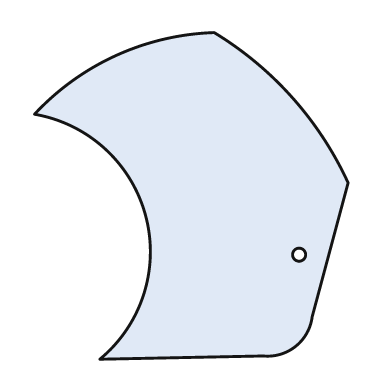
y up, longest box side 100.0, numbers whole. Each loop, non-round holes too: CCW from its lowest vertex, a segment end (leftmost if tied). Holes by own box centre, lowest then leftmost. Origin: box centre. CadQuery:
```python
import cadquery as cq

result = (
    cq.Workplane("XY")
    .moveTo(-28.0, -50.0)
    .lineTo(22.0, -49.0)
    .threePointArc((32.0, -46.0), (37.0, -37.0))
    .lineTo(48.0, 4.0)
    .threePointArc((31.0, 30.0), (7.0, 50.0))
    .threePointArc((-23.0, 43.0), (-48.0, 25.0))
    .threePointArc((-14.0, -6.0), (-28.0, -50.0))
    .close()
    .moveTo(33.0, -18.0)
    .circle(2.0)
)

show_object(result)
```